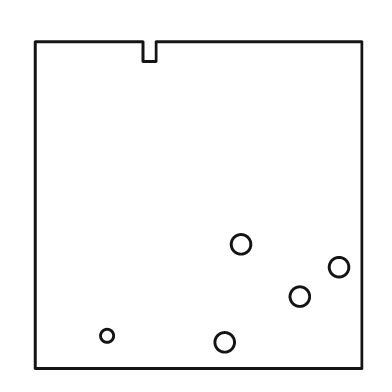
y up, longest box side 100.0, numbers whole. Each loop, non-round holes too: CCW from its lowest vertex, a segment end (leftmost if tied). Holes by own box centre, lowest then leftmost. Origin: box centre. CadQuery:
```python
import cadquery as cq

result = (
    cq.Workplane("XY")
    .moveTo(-50.0, -50.0)
    .lineTo(50.0, -50.0)
    .lineTo(50.0, 50.0)
    .lineTo(-13.0, 50.0)
    .lineTo(-13.0, 44.0)
    .lineTo(-17.0, 44.0)
    .lineTo(-17.0, 50.0)
    .lineTo(-50.0, 50.0)
    .close()
    .moveTo(8.0, -42.0)
    .circle(3.0)
    .moveTo(-28.0, -40.0)
    .circle(2.0)
    .moveTo(31.0, -28.0)
    .circle(3.0)
    .moveTo(43.0, -19.0)
    .circle(3.0)
    .moveTo(13.0, -12.0)
    .circle(3.0)
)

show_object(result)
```